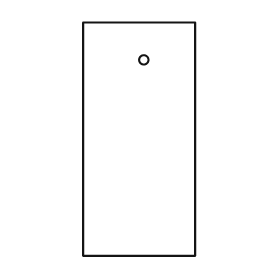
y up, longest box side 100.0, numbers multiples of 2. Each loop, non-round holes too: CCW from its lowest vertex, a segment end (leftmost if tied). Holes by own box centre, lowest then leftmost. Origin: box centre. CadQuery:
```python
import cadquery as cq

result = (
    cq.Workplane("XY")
    .moveTo(-24.0, -50.0)
    .lineTo(24.0, -50.0)
    .lineTo(24.0, 50.0)
    .lineTo(-24.0, 50.0)
    .close()
    .moveTo(2.0, 34.0)
    .circle(2.0)
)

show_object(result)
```